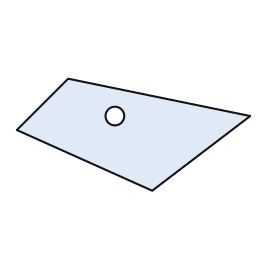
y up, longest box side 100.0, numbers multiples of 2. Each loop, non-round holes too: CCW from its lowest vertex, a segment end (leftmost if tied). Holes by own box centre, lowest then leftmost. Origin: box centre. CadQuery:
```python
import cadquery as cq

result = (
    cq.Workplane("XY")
    .moveTo(8.0, -24.0)
    .lineTo(50.0, 8.0)
    .lineTo(-28.0, 24.0)
    .lineTo(-50.0, 2.0)
    .close()
    .moveTo(-8.0, 8.0)
    .circle(4.0)
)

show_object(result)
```